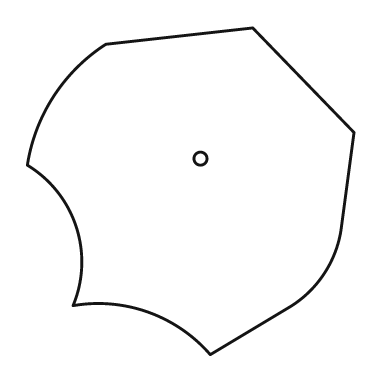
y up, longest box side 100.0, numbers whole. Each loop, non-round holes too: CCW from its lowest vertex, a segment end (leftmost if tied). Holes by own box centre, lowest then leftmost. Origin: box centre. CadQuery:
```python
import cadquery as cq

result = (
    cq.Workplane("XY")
    .moveTo(6.0, -50.0)
    .lineTo(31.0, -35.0)
    .threePointArc((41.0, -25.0), (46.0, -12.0))
    .lineTo(50.0, 18.0)
    .lineTo(19.0, 50.0)
    .lineTo(-26.0, 45.0)
    .threePointArc((-42.0, 29.0), (-50.0, 8.0))
    .threePointArc((-35.0, -11.0), (-36.0, -35.0))
    .threePointArc((-13.0, -37.0), (6.0, -50.0))
    .close()
    .moveTo(3.0, 10.0)
    .circle(2.0)
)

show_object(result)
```